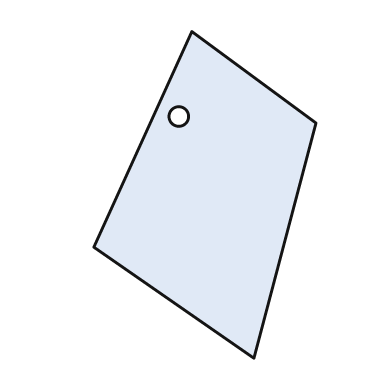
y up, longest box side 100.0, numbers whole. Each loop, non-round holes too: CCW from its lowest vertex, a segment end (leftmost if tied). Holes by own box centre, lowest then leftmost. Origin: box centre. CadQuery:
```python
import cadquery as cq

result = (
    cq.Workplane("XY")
    .moveTo(15.0, -50.0)
    .lineTo(34.0, 22.0)
    .lineTo(-4.0, 50.0)
    .lineTo(-34.0, -16.0)
    .close()
    .moveTo(-8.0, 24.0)
    .circle(3.0)
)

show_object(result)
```